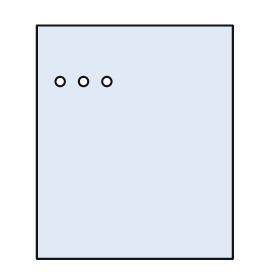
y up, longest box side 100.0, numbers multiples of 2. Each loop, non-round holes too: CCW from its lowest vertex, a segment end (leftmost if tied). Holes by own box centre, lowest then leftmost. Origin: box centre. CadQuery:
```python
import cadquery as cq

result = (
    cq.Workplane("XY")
    .moveTo(-42.0, -50.0)
    .lineTo(42.0, -50.0)
    .lineTo(42.0, 50.0)
    .lineTo(-42.0, 50.0)
    .close()
    .moveTo(-32.0, 26.0)
    .circle(2.0)
    .moveTo(-22.0, 26.0)
    .circle(2.0)
    .moveTo(-12.0, 26.0)
    .circle(2.0)
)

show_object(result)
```